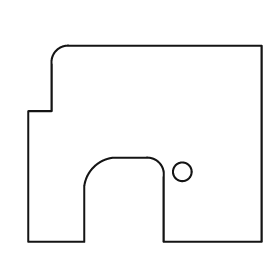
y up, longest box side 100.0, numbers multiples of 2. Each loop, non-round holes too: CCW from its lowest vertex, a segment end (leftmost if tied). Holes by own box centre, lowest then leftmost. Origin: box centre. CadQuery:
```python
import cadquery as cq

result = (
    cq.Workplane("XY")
    .moveTo(-50.0, -42.0)
    .lineTo(-26.0, -42.0)
    .lineTo(-26.0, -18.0)
    .threePointArc((-22.0, -10.0), (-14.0, -6.0))
    .lineTo(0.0, -6.0)
    .threePointArc((6.0, -8.0), (8.0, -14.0))
    .lineTo(8.0, -42.0)
    .lineTo(50.0, -42.0)
    .lineTo(50.0, 42.0)
    .lineTo(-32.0, 42.0)
    .threePointArc((-38.0, 40.0), (-40.0, 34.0))
    .lineTo(-40.0, 14.0)
    .lineTo(-50.0, 14.0)
    .close()
    .moveTo(16.0, -12.0)
    .circle(4.0)
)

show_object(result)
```